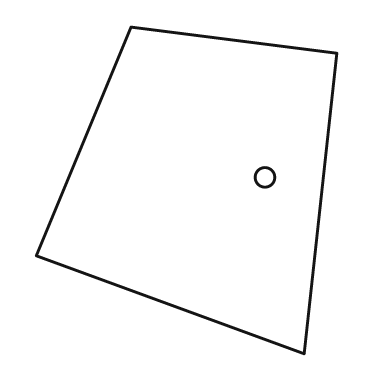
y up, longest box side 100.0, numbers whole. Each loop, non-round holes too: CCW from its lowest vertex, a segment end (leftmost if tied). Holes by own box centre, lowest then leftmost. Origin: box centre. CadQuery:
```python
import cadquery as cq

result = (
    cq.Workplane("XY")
    .moveTo(36.0, -50.0)
    .lineTo(46.0, 42.0)
    .lineTo(-17.0, 50.0)
    .lineTo(-46.0, -20.0)
    .close()
    .moveTo(24.0, 4.0)
    .circle(3.0)
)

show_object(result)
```